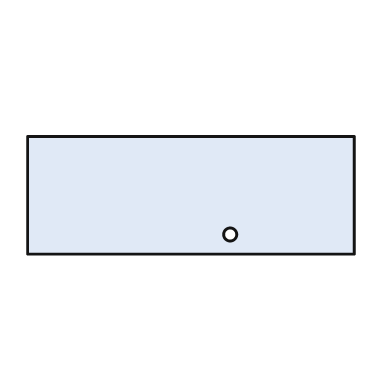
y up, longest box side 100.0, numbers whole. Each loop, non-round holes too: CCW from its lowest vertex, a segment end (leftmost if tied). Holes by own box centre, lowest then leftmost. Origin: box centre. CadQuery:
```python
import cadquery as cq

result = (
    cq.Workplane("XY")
    .moveTo(-50.0, -18.0)
    .lineTo(50.0, -18.0)
    .lineTo(50.0, 18.0)
    .lineTo(-50.0, 18.0)
    .close()
    .moveTo(12.0, -12.0)
    .circle(2.0)
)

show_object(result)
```